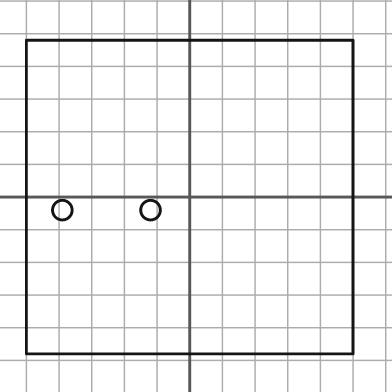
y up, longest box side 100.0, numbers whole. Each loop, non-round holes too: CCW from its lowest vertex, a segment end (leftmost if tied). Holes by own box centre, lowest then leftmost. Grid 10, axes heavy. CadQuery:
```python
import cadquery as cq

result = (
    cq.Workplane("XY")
    .moveTo(-50.0, -48.0)
    .lineTo(50.0, -48.0)
    .lineTo(50.0, 48.0)
    .lineTo(-50.0, 48.0)
    .close()
    .moveTo(-39.0, -4.0)
    .circle(3.0)
    .moveTo(-12.0, -4.0)
    .circle(3.0)
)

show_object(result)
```